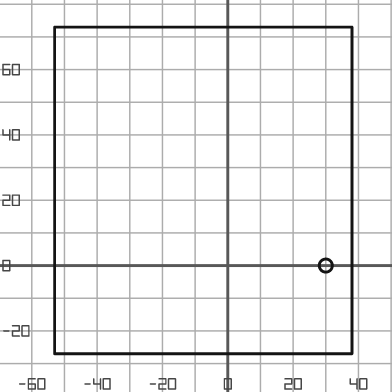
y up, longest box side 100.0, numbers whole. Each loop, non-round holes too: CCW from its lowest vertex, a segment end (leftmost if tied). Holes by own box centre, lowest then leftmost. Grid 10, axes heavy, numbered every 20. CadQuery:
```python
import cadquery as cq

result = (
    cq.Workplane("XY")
    .moveTo(-53.0, -27.0)
    .lineTo(38.0, -27.0)
    .lineTo(38.0, 73.0)
    .lineTo(-53.0, 73.0)
    .close()
    .moveTo(30.0, 0.0)
    .circle(2.0)
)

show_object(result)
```